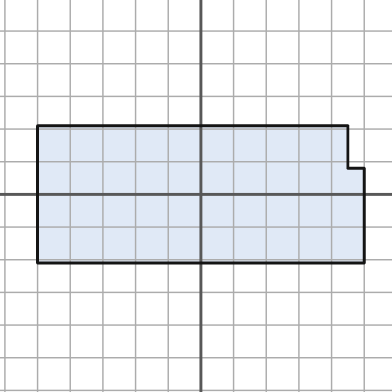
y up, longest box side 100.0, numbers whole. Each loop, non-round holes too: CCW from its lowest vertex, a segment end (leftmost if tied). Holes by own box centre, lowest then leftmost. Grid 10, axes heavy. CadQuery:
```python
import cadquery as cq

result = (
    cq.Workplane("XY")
    .moveTo(-50.0, -21.0)
    .lineTo(50.0, -21.0)
    .lineTo(50.0, 8.0)
    .lineTo(45.0, 8.0)
    .lineTo(45.0, 21.0)
    .lineTo(-50.0, 21.0)
    .close()
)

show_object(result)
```